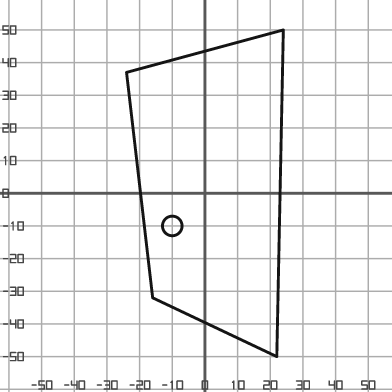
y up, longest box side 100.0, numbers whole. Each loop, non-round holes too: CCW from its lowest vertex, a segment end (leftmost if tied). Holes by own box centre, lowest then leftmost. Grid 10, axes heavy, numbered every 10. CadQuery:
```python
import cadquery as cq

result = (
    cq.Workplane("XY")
    .moveTo(22.0, -50.0)
    .lineTo(24.0, 50.0)
    .lineTo(-24.0, 37.0)
    .lineTo(-16.0, -32.0)
    .close()
    .moveTo(-10.0, -10.0)
    .circle(3.0)
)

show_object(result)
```